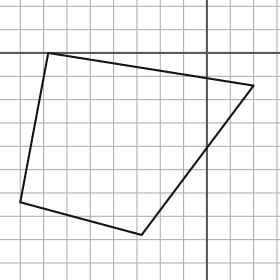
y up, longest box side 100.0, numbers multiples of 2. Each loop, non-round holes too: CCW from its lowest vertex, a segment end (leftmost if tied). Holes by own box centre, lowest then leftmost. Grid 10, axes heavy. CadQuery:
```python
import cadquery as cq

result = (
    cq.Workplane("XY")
    .moveTo(-28.0, -78.0)
    .lineTo(20.0, -14.0)
    .lineTo(-68.0, 0.0)
    .lineTo(-80.0, -64.0)
    .close()
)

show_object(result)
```